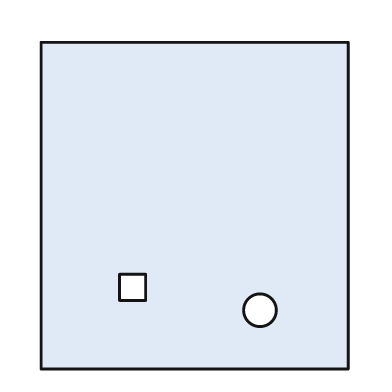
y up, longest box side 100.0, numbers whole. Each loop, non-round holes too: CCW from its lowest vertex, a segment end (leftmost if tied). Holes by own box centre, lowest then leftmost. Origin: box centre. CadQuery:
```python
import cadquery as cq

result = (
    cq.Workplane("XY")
    .moveTo(-47.0, -50.0)
    .lineTo(47.0, -50.0)
    .lineTo(47.0, 50.0)
    .lineTo(-47.0, 50.0)
    .close()
    .moveTo(20.0, -32.0)
    .circle(5.0)
    .moveTo(-23.0, -29.0)
    .lineTo(-15.0, -29.0)
    .lineTo(-15.0, -21.0)
    .lineTo(-23.0, -21.0)
    .close()
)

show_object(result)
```